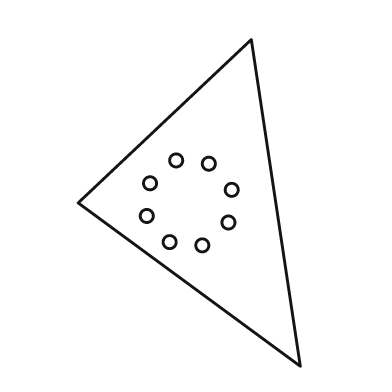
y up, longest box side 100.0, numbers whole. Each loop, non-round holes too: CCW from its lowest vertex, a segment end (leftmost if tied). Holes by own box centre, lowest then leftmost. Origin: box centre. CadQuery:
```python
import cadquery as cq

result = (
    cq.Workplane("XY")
    .moveTo(34.0, -50.0)
    .lineTo(19.0, 50.0)
    .lineTo(-34.0, 0.0)
    .close()
    .moveTo(4.0, -13.0)
    .circle(2.0)
    .moveTo(-6.0, -12.0)
    .circle(2.0)
    .moveTo(12.0, -6.0)
    .circle(2.0)
    .moveTo(-13.0, -4.0)
    .circle(2.0)
    .moveTo(13.0, 4.0)
    .circle(2.0)
    .moveTo(-12.0, 6.0)
    .circle(2.0)
    .moveTo(6.0, 12.0)
    .circle(2.0)
    .moveTo(-4.0, 13.0)
    .circle(2.0)
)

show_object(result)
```